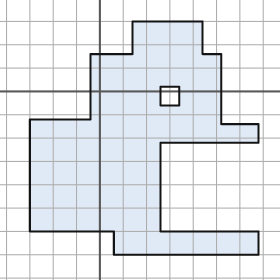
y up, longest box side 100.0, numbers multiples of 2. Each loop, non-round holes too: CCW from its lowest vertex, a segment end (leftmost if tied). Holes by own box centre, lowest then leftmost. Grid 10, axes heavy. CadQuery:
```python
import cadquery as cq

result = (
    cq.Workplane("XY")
    .moveTo(6.0, -70.0)
    .lineTo(68.0, -70.0)
    .lineTo(68.0, -60.0)
    .lineTo(26.0, -60.0)
    .lineTo(26.0, -22.0)
    .lineTo(68.0, -22.0)
    .lineTo(68.0, -14.0)
    .lineTo(52.0, -14.0)
    .lineTo(52.0, 16.0)
    .lineTo(44.0, 16.0)
    .lineTo(44.0, 30.0)
    .lineTo(14.0, 30.0)
    .lineTo(14.0, 16.0)
    .lineTo(-4.0, 16.0)
    .lineTo(-4.0, -12.0)
    .lineTo(-30.0, -12.0)
    .lineTo(-30.0, -60.0)
    .lineTo(6.0, -60.0)
    .close()
    .moveTo(26.0, -6.0)
    .lineTo(34.0, -6.0)
    .lineTo(34.0, 2.0)
    .lineTo(26.0, 2.0)
    .close()
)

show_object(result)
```